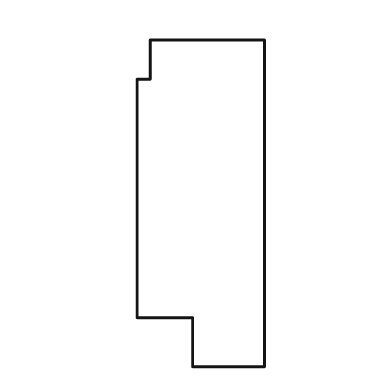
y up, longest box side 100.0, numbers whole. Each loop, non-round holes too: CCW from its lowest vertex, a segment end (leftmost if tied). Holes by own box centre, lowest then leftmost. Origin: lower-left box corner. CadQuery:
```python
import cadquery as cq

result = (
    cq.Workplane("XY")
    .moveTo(17.0, 0.0)
    .lineTo(39.0, 0.0)
    .lineTo(39.0, 100.0)
    .lineTo(4.0, 100.0)
    .lineTo(4.0, 88.0)
    .lineTo(0.0, 88.0)
    .lineTo(0.0, 15.0)
    .lineTo(17.0, 15.0)
    .close()
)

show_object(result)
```